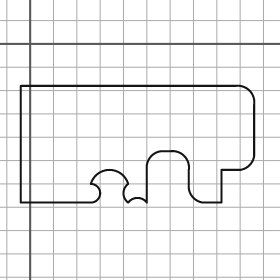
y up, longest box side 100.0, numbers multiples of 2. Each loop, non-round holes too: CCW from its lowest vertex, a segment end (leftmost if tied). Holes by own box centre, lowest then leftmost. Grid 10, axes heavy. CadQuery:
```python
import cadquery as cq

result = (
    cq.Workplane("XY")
    .moveTo(-4.0, -68.0)
    .lineTo(26.0, -68.0)
    .threePointArc((30.0, -64.0), (26.0, -60.0))
    .threePointArc((34.0, -54.0), (42.0, -60.0))
    .threePointArc((40.0, -64.0), (42.0, -68.0))
    .threePointArc((46.0, -66.0), (50.0, -68.0))
    .lineTo(50.0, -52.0)
    .threePointArc((52.0, -48.0), (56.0, -46.0))
    .lineTo(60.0, -46.0)
    .threePointArc((66.0, -48.0), (68.0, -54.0))
    .lineTo(68.0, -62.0)
    .threePointArc((70.0, -66.0), (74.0, -68.0))
    .lineTo(82.0, -68.0)
    .lineTo(82.0, -54.0)
    .lineTo(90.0, -54.0)
    .threePointArc((94.0, -52.0), (96.0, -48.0))
    .lineTo(96.0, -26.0)
    .threePointArc((94.0, -20.0), (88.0, -18.0))
    .lineTo(-4.0, -18.0)
    .close()
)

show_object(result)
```